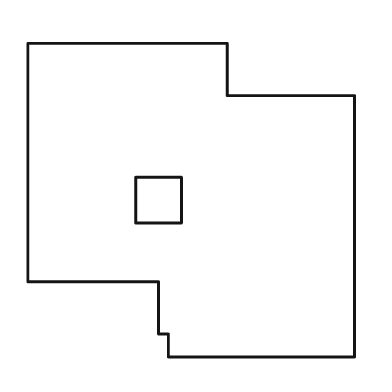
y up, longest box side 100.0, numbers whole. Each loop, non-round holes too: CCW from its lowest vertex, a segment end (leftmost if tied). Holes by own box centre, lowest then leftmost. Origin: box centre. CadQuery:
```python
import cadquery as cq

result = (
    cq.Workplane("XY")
    .moveTo(-7.0, -48.0)
    .lineTo(50.0, -48.0)
    .lineTo(50.0, 32.0)
    .lineTo(11.0, 32.0)
    .lineTo(11.0, 48.0)
    .lineTo(-50.0, 48.0)
    .lineTo(-50.0, -25.0)
    .lineTo(-10.0, -25.0)
    .lineTo(-10.0, -41.0)
    .lineTo(-7.0, -41.0)
    .close()
    .moveTo(-17.0, -7.0)
    .lineTo(-3.0, -7.0)
    .lineTo(-3.0, 7.0)
    .lineTo(-17.0, 7.0)
    .close()
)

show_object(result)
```